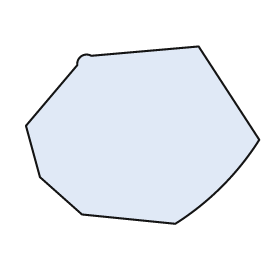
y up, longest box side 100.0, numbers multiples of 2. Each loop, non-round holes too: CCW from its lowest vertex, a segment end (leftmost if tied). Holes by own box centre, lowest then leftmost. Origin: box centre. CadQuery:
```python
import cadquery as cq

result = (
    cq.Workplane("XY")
    .moveTo(14.0, -38.0)
    .threePointArc((34.0, -22.0), (50.0, -2.0))
    .lineTo(24.0, 38.0)
    .lineTo(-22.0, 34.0)
    .threePointArc((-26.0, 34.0), (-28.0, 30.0))
    .lineTo(-50.0, 4.0)
    .lineTo(-44.0, -18.0)
    .lineTo(-26.0, -34.0)
    .close()
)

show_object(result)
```